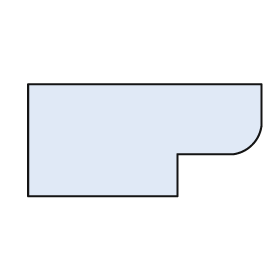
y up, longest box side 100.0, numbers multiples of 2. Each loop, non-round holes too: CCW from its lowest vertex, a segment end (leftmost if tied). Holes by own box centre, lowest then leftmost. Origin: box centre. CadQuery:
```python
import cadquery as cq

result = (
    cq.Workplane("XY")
    .moveTo(-50.0, -24.0)
    .lineTo(14.0, -24.0)
    .lineTo(14.0, -6.0)
    .lineTo(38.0, -6.0)
    .threePointArc((46.0, -2.0), (50.0, 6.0))
    .lineTo(50.0, 24.0)
    .lineTo(-50.0, 24.0)
    .close()
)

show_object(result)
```